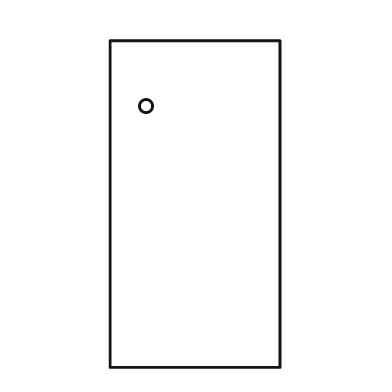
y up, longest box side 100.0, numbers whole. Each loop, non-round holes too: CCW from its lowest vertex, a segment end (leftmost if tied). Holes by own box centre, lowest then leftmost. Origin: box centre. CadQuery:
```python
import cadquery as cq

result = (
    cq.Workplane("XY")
    .moveTo(-26.0, -50.0)
    .lineTo(26.0, -50.0)
    .lineTo(26.0, 50.0)
    .lineTo(-26.0, 50.0)
    .close()
    .moveTo(-15.0, 30.0)
    .circle(2.0)
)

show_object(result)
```